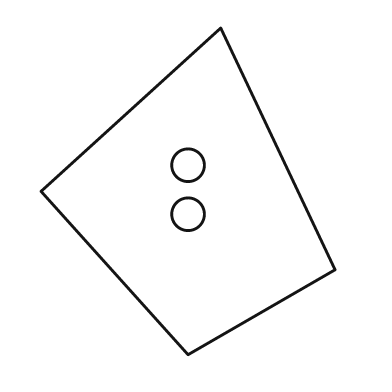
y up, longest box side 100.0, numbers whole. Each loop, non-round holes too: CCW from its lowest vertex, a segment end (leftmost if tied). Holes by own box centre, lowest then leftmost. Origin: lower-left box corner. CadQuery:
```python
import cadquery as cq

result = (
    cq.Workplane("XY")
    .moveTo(45.0, 0.0)
    .lineTo(90.0, 26.0)
    .lineTo(55.0, 100.0)
    .lineTo(0.0, 50.0)
    .close()
    .moveTo(45.0, 43.0)
    .circle(5.0)
    .moveTo(45.0, 58.0)
    .circle(5.0)
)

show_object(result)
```